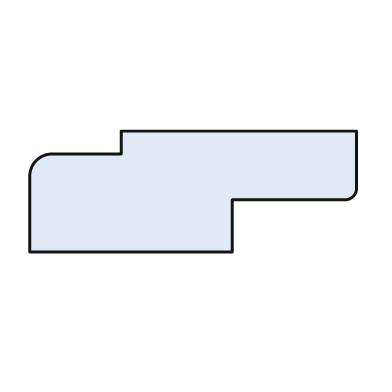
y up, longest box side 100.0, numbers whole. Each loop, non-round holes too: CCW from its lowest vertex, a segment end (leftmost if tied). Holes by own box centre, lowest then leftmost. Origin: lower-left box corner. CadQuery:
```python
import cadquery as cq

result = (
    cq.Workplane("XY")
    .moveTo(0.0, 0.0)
    .lineTo(62.0, 0.0)
    .lineTo(62.0, 16.0)
    .lineTo(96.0, 16.0)
    .threePointArc((99.0, 17.0), (100.0, 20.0))
    .lineTo(100.0, 37.0)
    .lineTo(28.0, 37.0)
    .lineTo(28.0, 30.0)
    .lineTo(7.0, 30.0)
    .threePointArc((2.0, 28.0), (0.0, 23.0))
    .close()
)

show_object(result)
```